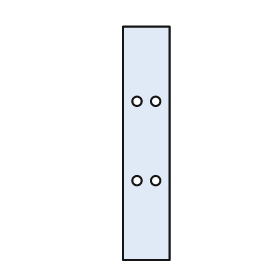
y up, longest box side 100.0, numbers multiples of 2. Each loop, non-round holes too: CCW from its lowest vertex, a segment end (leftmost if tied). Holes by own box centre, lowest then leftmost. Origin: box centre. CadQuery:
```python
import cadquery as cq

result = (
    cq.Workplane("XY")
    .moveTo(-10.0, -50.0)
    .lineTo(10.0, -50.0)
    .lineTo(10.0, 50.0)
    .lineTo(-10.0, 50.0)
    .close()
    .moveTo(-4.0, -16.0)
    .circle(2.0)
    .moveTo(4.0, -16.0)
    .circle(2.0)
    .moveTo(-4.0, 18.0)
    .circle(2.0)
    .moveTo(4.0, 18.0)
    .circle(2.0)
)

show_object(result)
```